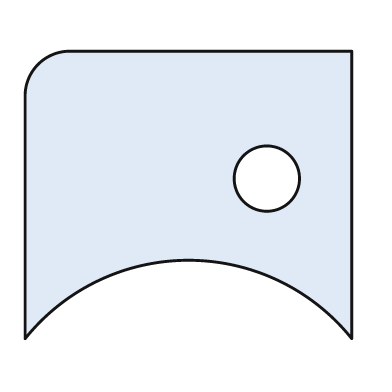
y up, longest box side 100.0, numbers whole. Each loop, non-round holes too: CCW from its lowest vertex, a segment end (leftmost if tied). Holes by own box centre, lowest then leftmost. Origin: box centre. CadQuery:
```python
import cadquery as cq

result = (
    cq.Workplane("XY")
    .moveTo(-50.0, -44.0)
    .threePointArc((0.0, -20.0), (50.0, -44.0))
    .lineTo(50.0, 44.0)
    .lineTo(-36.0, 44.0)
    .threePointArc((-46.0, 40.0), (-50.0, 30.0))
    .close()
    .moveTo(24.0, 5.0)
    .circle(10.0)
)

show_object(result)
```